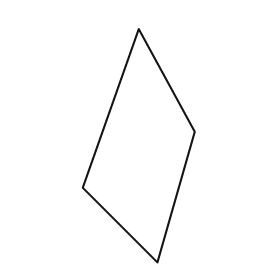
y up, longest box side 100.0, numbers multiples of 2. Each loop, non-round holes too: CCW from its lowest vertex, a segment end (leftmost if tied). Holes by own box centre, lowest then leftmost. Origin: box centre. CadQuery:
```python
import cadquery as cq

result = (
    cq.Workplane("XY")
    .moveTo(8.0, -50.0)
    .lineTo(24.0, 6.0)
    .lineTo(0.0, 50.0)
    .lineTo(-24.0, -18.0)
    .close()
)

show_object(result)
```